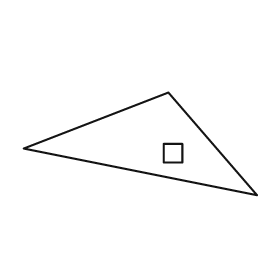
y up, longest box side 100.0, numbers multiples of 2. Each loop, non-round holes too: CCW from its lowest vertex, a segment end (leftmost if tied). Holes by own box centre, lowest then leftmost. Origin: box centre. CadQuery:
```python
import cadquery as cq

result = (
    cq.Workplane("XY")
    .moveTo(50.0, -22.0)
    .lineTo(12.0, 22.0)
    .lineTo(-50.0, -2.0)
    .close()
    .moveTo(10.0, -8.0)
    .lineTo(18.0, -8.0)
    .lineTo(18.0, 0.0)
    .lineTo(10.0, 0.0)
    .close()
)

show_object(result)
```